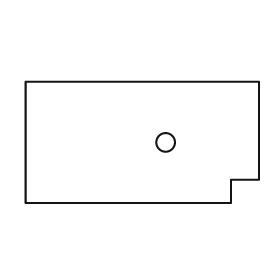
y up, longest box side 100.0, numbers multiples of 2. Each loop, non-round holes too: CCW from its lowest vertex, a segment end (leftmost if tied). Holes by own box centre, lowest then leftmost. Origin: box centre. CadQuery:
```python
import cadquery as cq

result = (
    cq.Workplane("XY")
    .moveTo(-50.0, -26.0)
    .lineTo(38.0, -26.0)
    .lineTo(38.0, -16.0)
    .lineTo(50.0, -16.0)
    .lineTo(50.0, 26.0)
    .lineTo(-50.0, 26.0)
    .close()
    .moveTo(10.0, 0.0)
    .circle(4.0)
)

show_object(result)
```